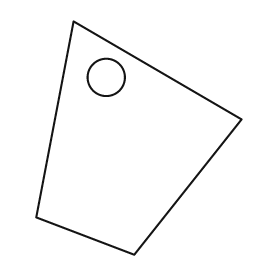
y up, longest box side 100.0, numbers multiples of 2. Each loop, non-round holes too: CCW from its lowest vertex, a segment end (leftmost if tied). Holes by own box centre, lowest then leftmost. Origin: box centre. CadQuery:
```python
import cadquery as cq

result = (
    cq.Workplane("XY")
    .moveTo(-2.0, -50.0)
    .lineTo(44.0, 8.0)
    .lineTo(-28.0, 50.0)
    .lineTo(-44.0, -34.0)
    .close()
    .moveTo(-14.0, 26.0)
    .circle(8.0)
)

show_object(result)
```